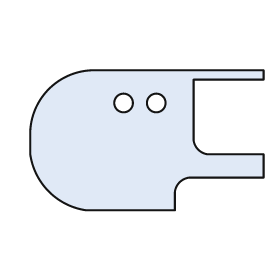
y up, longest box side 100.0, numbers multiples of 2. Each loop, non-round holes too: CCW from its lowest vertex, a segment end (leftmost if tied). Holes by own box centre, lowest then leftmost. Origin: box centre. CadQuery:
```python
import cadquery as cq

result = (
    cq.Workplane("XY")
    .moveTo(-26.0, -30.0)
    .lineTo(12.0, -30.0)
    .lineTo(12.0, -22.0)
    .threePointArc((14.0, -18.0), (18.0, -16.0))
    .lineTo(50.0, -16.0)
    .lineTo(50.0, -6.0)
    .lineTo(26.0, -6.0)
    .threePointArc((22.0, -4.0), (20.0, 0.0))
    .lineTo(20.0, 26.0)
    .lineTo(50.0, 26.0)
    .lineTo(50.0, 30.0)
    .lineTo(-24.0, 30.0)
    .threePointArc((-42.0, 22.0), (-50.0, 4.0))
    .lineTo(-50.0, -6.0)
    .threePointArc((-42.0, -22.0), (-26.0, -30.0))
    .close()
    .moveTo(-10.0, 16.0)
    .circle(4.0)
    .moveTo(4.0, 16.0)
    .circle(4.0)
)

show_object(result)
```